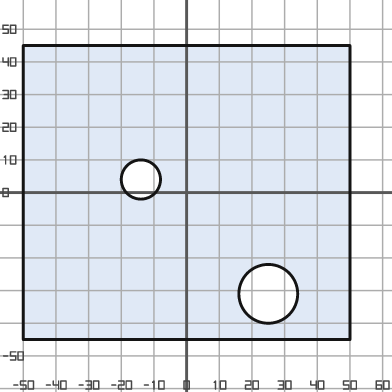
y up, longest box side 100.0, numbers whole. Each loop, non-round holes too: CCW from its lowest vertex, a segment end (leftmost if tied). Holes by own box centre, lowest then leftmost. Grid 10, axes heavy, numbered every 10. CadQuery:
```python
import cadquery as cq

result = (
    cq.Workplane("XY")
    .moveTo(-50.0, -45.0)
    .lineTo(50.0, -45.0)
    .lineTo(50.0, 45.0)
    .lineTo(-50.0, 45.0)
    .close()
    .moveTo(25.0, -31.0)
    .circle(9.0)
    .moveTo(-14.0, 4.0)
    .circle(6.0)
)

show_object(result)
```